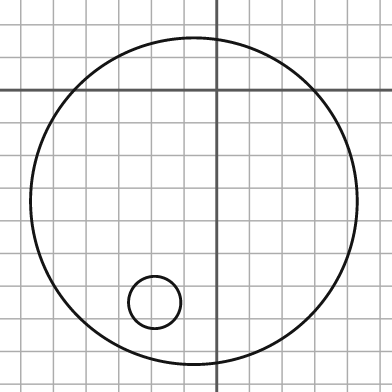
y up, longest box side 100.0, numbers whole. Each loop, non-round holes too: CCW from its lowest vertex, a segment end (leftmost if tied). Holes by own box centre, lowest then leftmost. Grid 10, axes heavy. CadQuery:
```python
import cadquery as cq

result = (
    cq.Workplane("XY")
    .moveTo(-7.0, -34.0)
    .circle(50.0)
    .moveTo(-19.0, -65.0)
    .circle(8.0)
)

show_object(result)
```